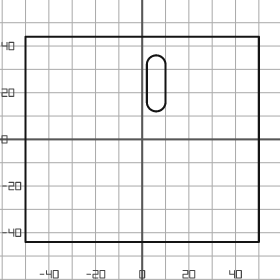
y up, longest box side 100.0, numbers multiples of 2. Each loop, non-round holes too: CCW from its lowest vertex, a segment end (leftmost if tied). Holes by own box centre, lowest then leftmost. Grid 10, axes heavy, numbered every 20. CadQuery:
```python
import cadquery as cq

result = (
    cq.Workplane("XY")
    .moveTo(-50.0, -44.0)
    .lineTo(50.0, -44.0)
    .lineTo(50.0, 44.0)
    .lineTo(-50.0, 44.0)
    .close()
    .moveTo(2.0, 16.0)
    .threePointArc((6.0, 12.0), (10.0, 16.0))
    .lineTo(10.0, 32.0)
    .threePointArc((6.0, 36.0), (2.0, 32.0))
    .close()
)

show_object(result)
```